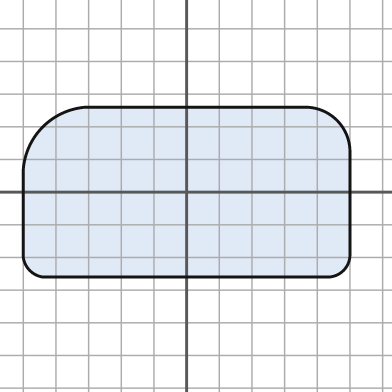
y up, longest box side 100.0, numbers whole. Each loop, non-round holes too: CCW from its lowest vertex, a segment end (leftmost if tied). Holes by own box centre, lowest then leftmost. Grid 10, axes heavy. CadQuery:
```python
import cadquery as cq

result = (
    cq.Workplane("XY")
    .moveTo(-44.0, -26.0)
    .lineTo(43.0, -26.0)
    .threePointArc((48.0, -24.0), (50.0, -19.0))
    .lineTo(50.0, 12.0)
    .threePointArc((46.0, 22.0), (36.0, 26.0))
    .lineTo(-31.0, 26.0)
    .threePointArc((-44.0, 20.0), (-50.0, 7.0))
    .lineTo(-50.0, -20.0)
    .threePointArc((-48.0, -24.0), (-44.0, -26.0))
    .close()
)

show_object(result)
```